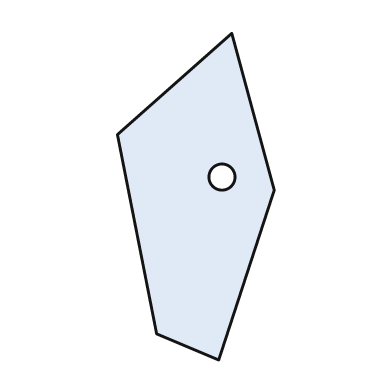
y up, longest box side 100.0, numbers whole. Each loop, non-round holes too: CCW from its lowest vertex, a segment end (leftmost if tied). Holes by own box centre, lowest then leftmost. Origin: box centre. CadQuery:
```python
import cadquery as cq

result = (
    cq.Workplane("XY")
    .moveTo(7.0, -50.0)
    .lineTo(24.0, 2.0)
    .lineTo(11.0, 50.0)
    .lineTo(-24.0, 19.0)
    .lineTo(-12.0, -42.0)
    .close()
    .moveTo(8.0, 6.0)
    .circle(4.0)
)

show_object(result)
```